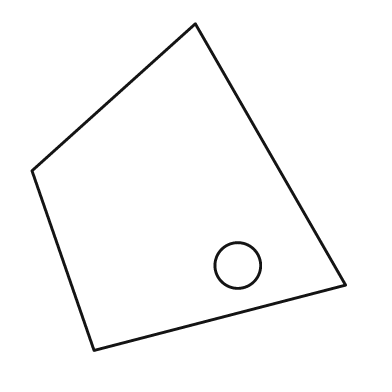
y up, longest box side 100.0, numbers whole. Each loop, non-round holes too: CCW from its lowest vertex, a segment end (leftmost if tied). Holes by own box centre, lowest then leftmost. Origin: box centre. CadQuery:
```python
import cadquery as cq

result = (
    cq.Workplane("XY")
    .moveTo(-29.0, -50.0)
    .lineTo(48.0, -30.0)
    .lineTo(2.0, 50.0)
    .lineTo(-48.0, 5.0)
    .close()
    .moveTo(15.0, -24.0)
    .circle(7.0)
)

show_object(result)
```